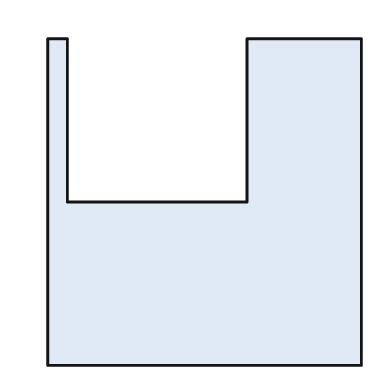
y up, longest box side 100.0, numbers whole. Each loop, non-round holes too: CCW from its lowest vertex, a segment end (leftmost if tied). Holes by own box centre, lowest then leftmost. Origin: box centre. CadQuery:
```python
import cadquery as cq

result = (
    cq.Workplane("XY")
    .moveTo(-48.0, -50.0)
    .lineTo(48.0, -50.0)
    .lineTo(48.0, 50.0)
    .lineTo(13.0, 50.0)
    .lineTo(13.0, 0.0)
    .lineTo(-42.0, 0.0)
    .lineTo(-42.0, 50.0)
    .lineTo(-48.0, 50.0)
    .close()
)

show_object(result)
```